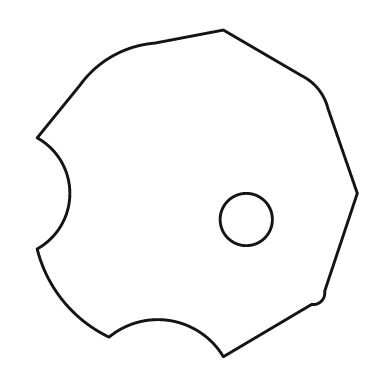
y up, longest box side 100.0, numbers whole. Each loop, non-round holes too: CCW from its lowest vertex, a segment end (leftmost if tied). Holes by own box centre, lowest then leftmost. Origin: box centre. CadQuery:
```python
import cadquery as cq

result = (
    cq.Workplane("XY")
    .moveTo(8.0, -50.0)
    .lineTo(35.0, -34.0)
    .threePointArc((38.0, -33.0), (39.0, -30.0))
    .lineTo(49.0, 0.0)
    .lineTo(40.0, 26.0)
    .threePointArc((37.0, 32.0), (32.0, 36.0))
    .lineTo(8.0, 50.0)
    .lineTo(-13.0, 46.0)
    .threePointArc((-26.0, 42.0), (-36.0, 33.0))
    .lineTo(-49.0, 17.0)
    .threePointArc((-39.0, 0.0), (-49.0, -17.0))
    .threePointArc((-41.0, -33.0), (-27.0, -44.0))
    .threePointArc((-8.0, -39.0), (8.0, -50.0))
    .close()
    .moveTo(15.0, -8.0)
    .circle(8.0)
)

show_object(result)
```